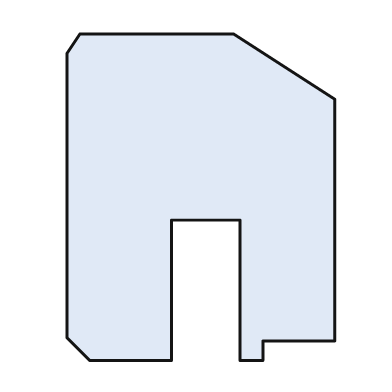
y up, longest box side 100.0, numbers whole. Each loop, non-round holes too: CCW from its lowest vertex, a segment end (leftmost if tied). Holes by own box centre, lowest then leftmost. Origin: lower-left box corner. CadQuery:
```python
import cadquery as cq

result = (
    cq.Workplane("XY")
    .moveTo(7.0, 0.0)
    .lineTo(32.0, 0.0)
    .lineTo(32.0, 43.0)
    .lineTo(53.0, 43.0)
    .lineTo(53.0, 0.0)
    .lineTo(60.0, 0.0)
    .lineTo(60.0, 6.0)
    .lineTo(82.0, 6.0)
    .lineTo(82.0, 80.0)
    .lineTo(51.0, 100.0)
    .lineTo(4.0, 100.0)
    .lineTo(0.0, 94.0)
    .lineTo(0.0, 7.0)
    .close()
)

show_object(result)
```